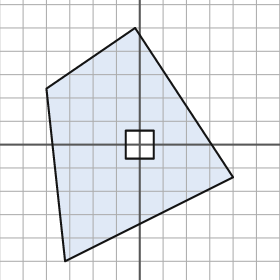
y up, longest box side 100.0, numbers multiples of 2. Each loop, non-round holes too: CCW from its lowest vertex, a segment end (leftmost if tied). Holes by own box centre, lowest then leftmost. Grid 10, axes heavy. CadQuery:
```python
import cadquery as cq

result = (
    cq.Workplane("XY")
    .moveTo(-32.0, -50.0)
    .lineTo(40.0, -14.0)
    .lineTo(-2.0, 50.0)
    .lineTo(-40.0, 24.0)
    .close()
    .moveTo(-6.0, -6.0)
    .lineTo(6.0, -6.0)
    .lineTo(6.0, 6.0)
    .lineTo(-6.0, 6.0)
    .close()
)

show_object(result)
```